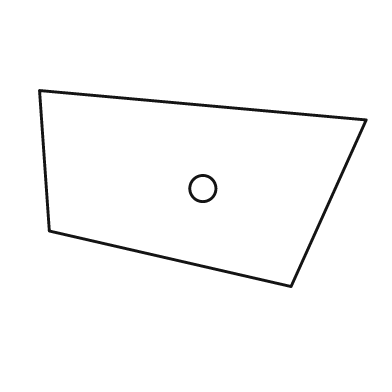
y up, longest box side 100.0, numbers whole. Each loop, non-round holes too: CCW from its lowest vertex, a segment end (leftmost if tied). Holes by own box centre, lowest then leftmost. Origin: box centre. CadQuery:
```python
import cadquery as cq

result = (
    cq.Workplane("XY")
    .moveTo(27.0, -30.0)
    .lineTo(50.0, 21.0)
    .lineTo(-50.0, 30.0)
    .lineTo(-47.0, -13.0)
    .close()
    .moveTo(0.0, 0.0)
    .circle(4.0)
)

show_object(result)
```